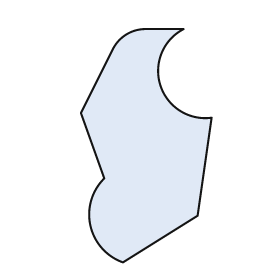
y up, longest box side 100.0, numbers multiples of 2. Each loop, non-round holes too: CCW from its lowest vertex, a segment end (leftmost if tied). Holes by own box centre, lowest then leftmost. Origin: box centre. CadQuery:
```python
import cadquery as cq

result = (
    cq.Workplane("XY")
    .moveTo(-10.0, -50.0)
    .lineTo(22.0, -30.0)
    .lineTo(28.0, 12.0)
    .threePointArc((6.0, 26.0), (16.0, 50.0))
    .lineTo(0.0, 50.0)
    .threePointArc((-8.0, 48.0), (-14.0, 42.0))
    .lineTo(-28.0, 14.0)
    .lineTo(-18.0, -14.0)
    .threePointArc((-24.0, -34.0), (-10.0, -50.0))
    .close()
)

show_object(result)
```